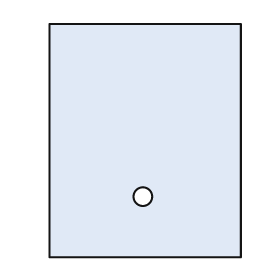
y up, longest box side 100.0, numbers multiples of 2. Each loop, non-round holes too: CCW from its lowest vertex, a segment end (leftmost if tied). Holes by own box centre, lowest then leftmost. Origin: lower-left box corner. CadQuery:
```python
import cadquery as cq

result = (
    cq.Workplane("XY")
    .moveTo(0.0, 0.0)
    .lineTo(82.0, 0.0)
    .lineTo(82.0, 100.0)
    .lineTo(0.0, 100.0)
    .close()
    .moveTo(40.0, 26.0)
    .circle(4.0)
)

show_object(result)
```